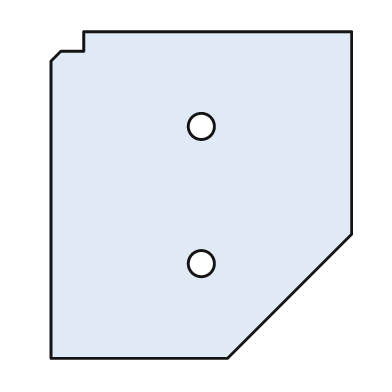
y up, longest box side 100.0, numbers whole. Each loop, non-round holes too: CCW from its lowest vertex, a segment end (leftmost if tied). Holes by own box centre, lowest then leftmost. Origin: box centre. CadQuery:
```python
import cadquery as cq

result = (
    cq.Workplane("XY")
    .moveTo(-46.0, -50.0)
    .lineTo(8.0, -50.0)
    .lineTo(46.0, -12.0)
    .lineTo(46.0, 50.0)
    .lineTo(-36.0, 50.0)
    .lineTo(-36.0, 44.0)
    .lineTo(-43.0, 44.0)
    .lineTo(-46.0, 41.0)
    .close()
    .moveTo(0.0, -21.0)
    .circle(4.0)
    .moveTo(0.0, 21.0)
    .circle(4.0)
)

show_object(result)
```